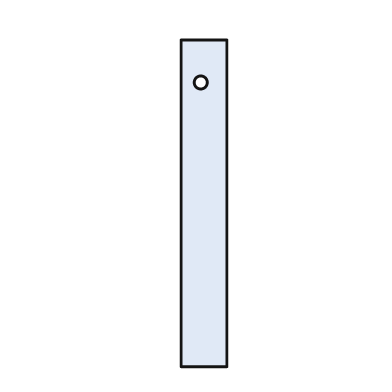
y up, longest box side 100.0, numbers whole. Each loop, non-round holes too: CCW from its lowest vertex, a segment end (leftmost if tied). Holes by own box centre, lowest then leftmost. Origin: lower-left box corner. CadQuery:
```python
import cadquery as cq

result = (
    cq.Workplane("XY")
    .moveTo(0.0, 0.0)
    .lineTo(14.0, 0.0)
    .lineTo(14.0, 100.0)
    .lineTo(0.0, 100.0)
    .close()
    .moveTo(6.0, 87.0)
    .circle(2.0)
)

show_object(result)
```